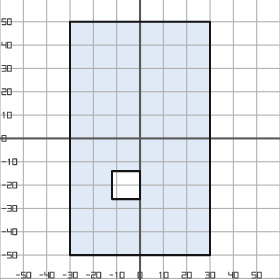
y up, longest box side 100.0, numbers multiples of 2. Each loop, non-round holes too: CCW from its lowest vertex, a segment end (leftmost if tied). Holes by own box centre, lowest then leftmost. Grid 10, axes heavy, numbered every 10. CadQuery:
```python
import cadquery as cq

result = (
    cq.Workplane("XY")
    .moveTo(-30.0, -50.0)
    .lineTo(30.0, -50.0)
    .lineTo(30.0, 50.0)
    .lineTo(-30.0, 50.0)
    .close()
    .moveTo(-12.0, -26.0)
    .lineTo(0.0, -26.0)
    .lineTo(0.0, -14.0)
    .lineTo(-12.0, -14.0)
    .close()
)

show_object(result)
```